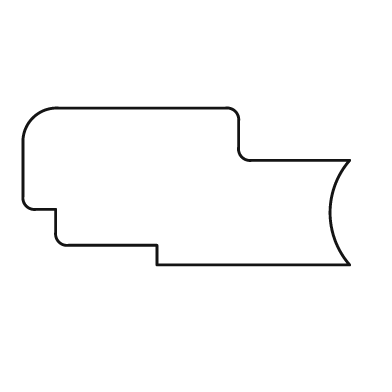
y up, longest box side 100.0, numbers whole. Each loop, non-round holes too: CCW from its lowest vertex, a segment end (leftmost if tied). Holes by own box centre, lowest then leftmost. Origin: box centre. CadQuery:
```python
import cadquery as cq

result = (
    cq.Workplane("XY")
    .moveTo(-9.0, -24.0)
    .lineTo(50.0, -24.0)
    .threePointArc((44.0, -8.0), (50.0, 8.0))
    .lineTo(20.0, 8.0)
    .threePointArc((17.0, 9.0), (16.0, 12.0))
    .lineTo(16.0, 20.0)
    .threePointArc((15.0, 23.0), (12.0, 24.0))
    .lineTo(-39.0, 24.0)
    .threePointArc((-47.0, 21.0), (-50.0, 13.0))
    .lineTo(-50.0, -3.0)
    .threePointArc((-49.0, -6.0), (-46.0, -7.0))
    .lineTo(-40.0, -7.0)
    .lineTo(-40.0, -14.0)
    .threePointArc((-39.0, -17.0), (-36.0, -18.0))
    .lineTo(-9.0, -18.0)
    .close()
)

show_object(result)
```